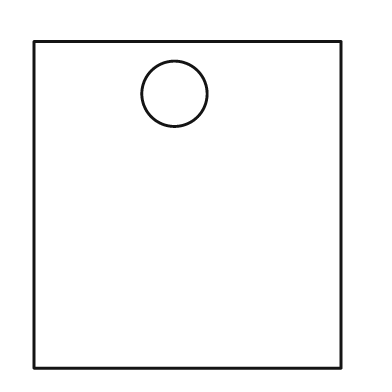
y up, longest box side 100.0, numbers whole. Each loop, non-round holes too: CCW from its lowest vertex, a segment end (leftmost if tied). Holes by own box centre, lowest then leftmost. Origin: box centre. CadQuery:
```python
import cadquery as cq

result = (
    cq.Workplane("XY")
    .moveTo(-47.0, -50.0)
    .lineTo(47.0, -50.0)
    .lineTo(47.0, 50.0)
    .lineTo(-47.0, 50.0)
    .close()
    .moveTo(-4.0, 34.0)
    .circle(10.0)
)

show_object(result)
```